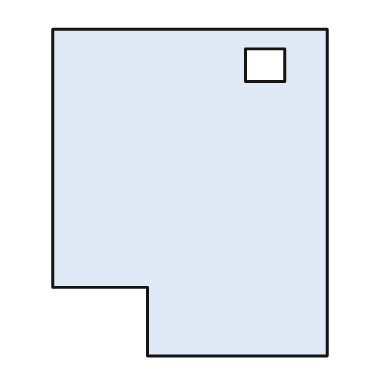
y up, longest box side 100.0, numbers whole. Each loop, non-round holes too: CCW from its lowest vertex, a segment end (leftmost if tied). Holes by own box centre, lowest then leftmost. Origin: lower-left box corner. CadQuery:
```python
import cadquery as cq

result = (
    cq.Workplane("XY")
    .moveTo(29.0, 0.0)
    .lineTo(84.0, 0.0)
    .lineTo(84.0, 100.0)
    .lineTo(0.0, 100.0)
    .lineTo(0.0, 21.0)
    .lineTo(29.0, 21.0)
    .close()
    .moveTo(59.0, 84.0)
    .lineTo(71.0, 84.0)
    .lineTo(71.0, 94.0)
    .lineTo(59.0, 94.0)
    .close()
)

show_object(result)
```